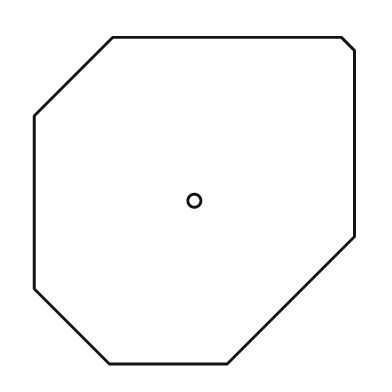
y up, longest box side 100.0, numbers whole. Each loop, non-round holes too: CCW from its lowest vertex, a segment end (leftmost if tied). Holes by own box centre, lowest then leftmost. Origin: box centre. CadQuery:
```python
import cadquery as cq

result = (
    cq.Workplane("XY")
    .moveTo(-26.0, -50.0)
    .lineTo(10.0, -50.0)
    .lineTo(49.0, -11.0)
    .lineTo(49.0, 46.0)
    .lineTo(45.0, 50.0)
    .lineTo(-25.0, 50.0)
    .lineTo(-49.0, 26.0)
    .lineTo(-49.0, -27.0)
    .close()
    .moveTo(0.0, 0.0)
    .circle(2.0)
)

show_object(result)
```